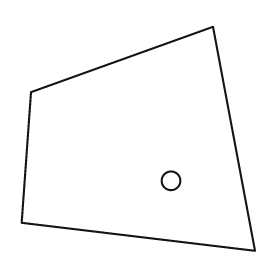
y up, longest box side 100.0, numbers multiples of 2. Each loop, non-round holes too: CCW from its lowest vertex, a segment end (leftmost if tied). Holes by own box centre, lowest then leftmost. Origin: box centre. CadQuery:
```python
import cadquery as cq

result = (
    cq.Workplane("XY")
    .moveTo(50.0, -48.0)
    .lineTo(32.0, 48.0)
    .lineTo(-46.0, 20.0)
    .lineTo(-50.0, -36.0)
    .close()
    .moveTo(14.0, -18.0)
    .circle(4.0)
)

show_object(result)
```